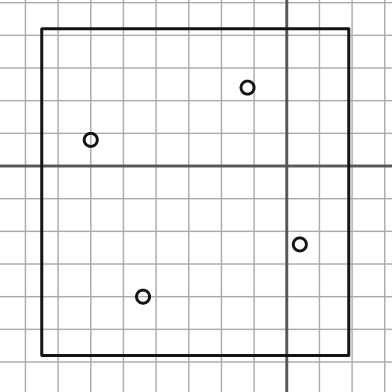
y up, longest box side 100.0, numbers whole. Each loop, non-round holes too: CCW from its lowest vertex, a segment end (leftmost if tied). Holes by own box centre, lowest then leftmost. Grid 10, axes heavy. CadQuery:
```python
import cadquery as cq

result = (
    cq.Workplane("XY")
    .moveTo(-75.0, -58.0)
    .lineTo(19.0, -58.0)
    .lineTo(19.0, 42.0)
    .lineTo(-75.0, 42.0)
    .close()
    .moveTo(-44.0, -40.0)
    .circle(2.0)
    .moveTo(4.0, -24.0)
    .circle(2.0)
    .moveTo(-60.0, 8.0)
    .circle(2.0)
    .moveTo(-12.0, 24.0)
    .circle(2.0)
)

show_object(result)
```